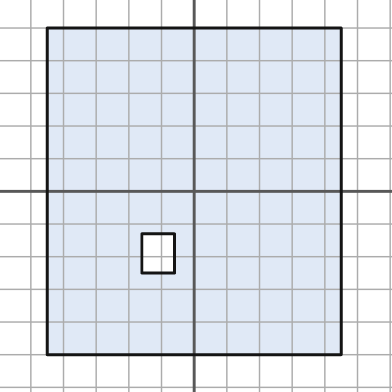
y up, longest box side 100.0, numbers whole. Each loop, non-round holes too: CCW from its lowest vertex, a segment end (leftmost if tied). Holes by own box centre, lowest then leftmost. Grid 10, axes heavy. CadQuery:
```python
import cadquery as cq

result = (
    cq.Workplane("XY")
    .moveTo(-45.0, -50.0)
    .lineTo(45.0, -50.0)
    .lineTo(45.0, 50.0)
    .lineTo(-45.0, 50.0)
    .close()
    .moveTo(-16.0, -25.0)
    .lineTo(-6.0, -25.0)
    .lineTo(-6.0, -13.0)
    .lineTo(-16.0, -13.0)
    .close()
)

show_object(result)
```